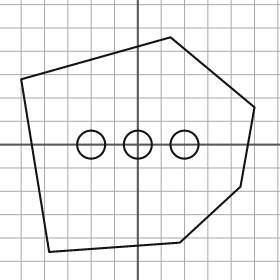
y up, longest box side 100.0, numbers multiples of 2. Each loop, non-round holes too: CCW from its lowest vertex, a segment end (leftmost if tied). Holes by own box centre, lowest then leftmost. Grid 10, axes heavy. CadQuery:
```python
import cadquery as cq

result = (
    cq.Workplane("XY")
    .moveTo(-38.0, -46.0)
    .lineTo(18.0, -42.0)
    .lineTo(44.0, -18.0)
    .lineTo(50.0, 16.0)
    .lineTo(14.0, 46.0)
    .lineTo(-50.0, 28.0)
    .close()
    .moveTo(-20.0, 0.0)
    .circle(6.0)
    .moveTo(0.0, 0.0)
    .circle(6.0)
    .moveTo(20.0, 0.0)
    .circle(6.0)
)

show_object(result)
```